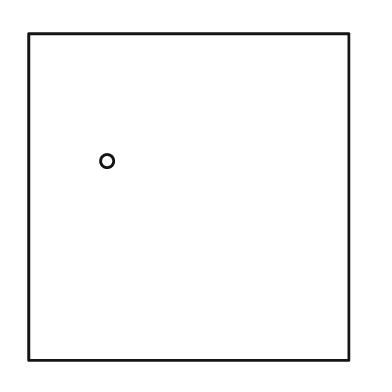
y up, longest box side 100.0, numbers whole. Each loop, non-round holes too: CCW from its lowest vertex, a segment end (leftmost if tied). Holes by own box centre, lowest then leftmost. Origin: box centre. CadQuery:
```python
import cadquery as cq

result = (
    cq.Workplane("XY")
    .moveTo(-49.0, -50.0)
    .lineTo(49.0, -50.0)
    .lineTo(49.0, 50.0)
    .lineTo(-49.0, 50.0)
    .close()
    .moveTo(-25.0, 11.0)
    .circle(2.0)
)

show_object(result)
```